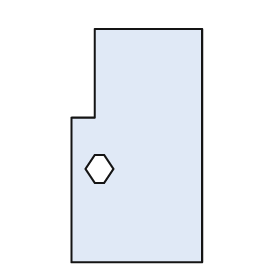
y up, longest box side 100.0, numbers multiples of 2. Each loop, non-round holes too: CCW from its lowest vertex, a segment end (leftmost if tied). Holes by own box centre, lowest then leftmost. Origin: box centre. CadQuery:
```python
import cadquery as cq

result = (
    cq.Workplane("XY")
    .moveTo(-28.0, -50.0)
    .lineTo(28.0, -50.0)
    .lineTo(28.0, 50.0)
    .lineTo(-18.0, 50.0)
    .lineTo(-18.0, 12.0)
    .lineTo(-28.0, 12.0)
    .close()
    .moveTo(-18.0, -16.0)
    .lineTo(-14.0, -16.0)
    .lineTo(-10.0, -10.0)
    .lineTo(-14.0, -4.0)
    .lineTo(-18.0, -4.0)
    .lineTo(-22.0, -10.0)
    .close()
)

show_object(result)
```